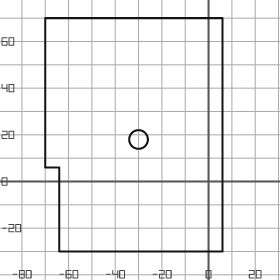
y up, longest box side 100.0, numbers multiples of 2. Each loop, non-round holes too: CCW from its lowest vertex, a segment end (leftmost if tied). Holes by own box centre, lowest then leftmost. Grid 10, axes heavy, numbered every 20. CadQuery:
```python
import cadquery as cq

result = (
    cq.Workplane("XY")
    .moveTo(-64.0, -30.0)
    .lineTo(6.0, -30.0)
    .lineTo(6.0, 70.0)
    .lineTo(-70.0, 70.0)
    .lineTo(-70.0, 6.0)
    .lineTo(-64.0, 6.0)
    .close()
    .moveTo(-30.0, 18.0)
    .circle(4.0)
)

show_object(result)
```